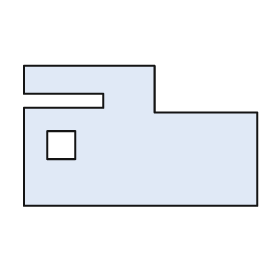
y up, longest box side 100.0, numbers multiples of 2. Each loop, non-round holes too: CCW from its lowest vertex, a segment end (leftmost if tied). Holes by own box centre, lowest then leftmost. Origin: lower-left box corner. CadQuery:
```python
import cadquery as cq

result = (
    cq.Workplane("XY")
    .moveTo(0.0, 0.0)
    .lineTo(100.0, 0.0)
    .lineTo(100.0, 40.0)
    .lineTo(56.0, 40.0)
    .lineTo(56.0, 60.0)
    .lineTo(0.0, 60.0)
    .lineTo(0.0, 48.0)
    .lineTo(34.0, 48.0)
    .lineTo(34.0, 42.0)
    .lineTo(0.0, 42.0)
    .close()
    .moveTo(10.0, 20.0)
    .lineTo(22.0, 20.0)
    .lineTo(22.0, 32.0)
    .lineTo(10.0, 32.0)
    .close()
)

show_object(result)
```